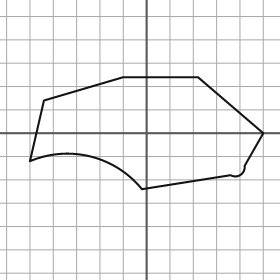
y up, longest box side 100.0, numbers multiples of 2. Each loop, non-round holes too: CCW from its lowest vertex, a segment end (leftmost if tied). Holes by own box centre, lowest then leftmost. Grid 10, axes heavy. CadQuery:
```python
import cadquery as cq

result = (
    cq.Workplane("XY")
    .moveTo(-2.0, -24.0)
    .lineTo(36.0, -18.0)
    .threePointArc((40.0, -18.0), (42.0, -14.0))
    .lineTo(50.0, 0.0)
    .lineTo(22.0, 24.0)
    .lineTo(-10.0, 24.0)
    .lineTo(-44.0, 14.0)
    .lineTo(-50.0, -12.0)
    .threePointArc((-24.0, -10.0), (-2.0, -24.0))
    .close()
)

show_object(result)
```